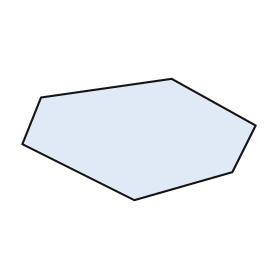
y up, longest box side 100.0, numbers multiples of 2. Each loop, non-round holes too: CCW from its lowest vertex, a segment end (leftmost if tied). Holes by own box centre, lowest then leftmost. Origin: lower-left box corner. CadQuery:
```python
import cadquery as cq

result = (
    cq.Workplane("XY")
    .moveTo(48.0, 0.0)
    .lineTo(90.0, 12.0)
    .lineTo(100.0, 32.0)
    .lineTo(64.0, 52.0)
    .lineTo(8.0, 44.0)
    .lineTo(0.0, 24.0)
    .close()
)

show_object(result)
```